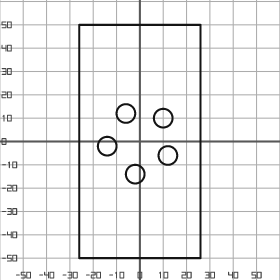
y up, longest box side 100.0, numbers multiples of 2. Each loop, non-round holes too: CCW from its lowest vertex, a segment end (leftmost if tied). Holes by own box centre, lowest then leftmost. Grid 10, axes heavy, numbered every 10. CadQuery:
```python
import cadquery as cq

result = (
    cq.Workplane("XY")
    .moveTo(-26.0, -50.0)
    .lineTo(26.0, -50.0)
    .lineTo(26.0, 50.0)
    .lineTo(-26.0, 50.0)
    .close()
    .moveTo(-2.0, -14.0)
    .circle(4.0)
    .moveTo(12.0, -6.0)
    .circle(4.0)
    .moveTo(-14.0, -2.0)
    .circle(4.0)
    .moveTo(10.0, 10.0)
    .circle(4.0)
    .moveTo(-6.0, 12.0)
    .circle(4.0)
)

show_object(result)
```